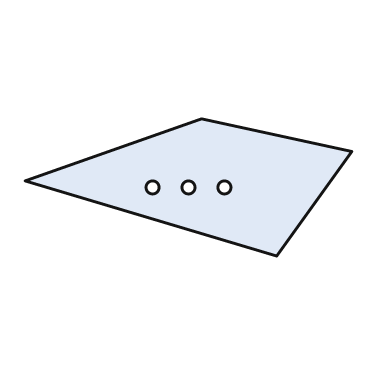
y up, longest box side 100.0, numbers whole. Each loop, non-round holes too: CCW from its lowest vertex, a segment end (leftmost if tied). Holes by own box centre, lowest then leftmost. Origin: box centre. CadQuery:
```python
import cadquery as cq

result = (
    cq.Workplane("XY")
    .moveTo(27.0, -21.0)
    .lineTo(50.0, 11.0)
    .lineTo(4.0, 21.0)
    .lineTo(-50.0, 2.0)
    .close()
    .moveTo(-11.0, 0.0)
    .circle(2.0)
    .moveTo(0.0, 0.0)
    .circle(2.0)
    .moveTo(11.0, 0.0)
    .circle(2.0)
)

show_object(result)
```